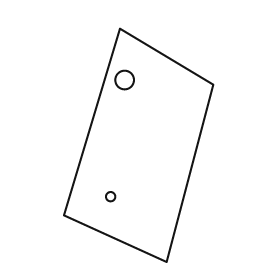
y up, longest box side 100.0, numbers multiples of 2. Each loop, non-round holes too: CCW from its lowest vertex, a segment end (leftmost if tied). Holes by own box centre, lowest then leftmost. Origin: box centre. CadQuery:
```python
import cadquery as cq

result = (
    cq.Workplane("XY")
    .moveTo(12.0, -50.0)
    .lineTo(32.0, 26.0)
    .lineTo(-8.0, 50.0)
    .lineTo(-32.0, -30.0)
    .close()
    .moveTo(-12.0, -22.0)
    .circle(2.0)
    .moveTo(-6.0, 28.0)
    .circle(4.0)
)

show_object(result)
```